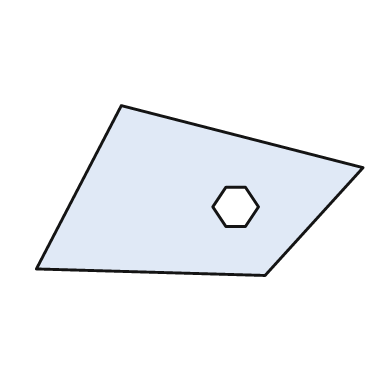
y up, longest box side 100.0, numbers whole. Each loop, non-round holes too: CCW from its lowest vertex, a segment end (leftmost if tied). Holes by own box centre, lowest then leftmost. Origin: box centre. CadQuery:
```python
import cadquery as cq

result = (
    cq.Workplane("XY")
    .moveTo(20.0, -26.0)
    .lineTo(50.0, 7.0)
    .lineTo(-24.0, 26.0)
    .lineTo(-50.0, -24.0)
    .close()
    .moveTo(8.0, -11.0)
    .lineTo(14.0, -11.0)
    .lineTo(18.0, -5.0)
    .lineTo(14.0, 1.0)
    .lineTo(8.0, 1.0)
    .lineTo(4.0, -5.0)
    .close()
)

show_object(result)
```